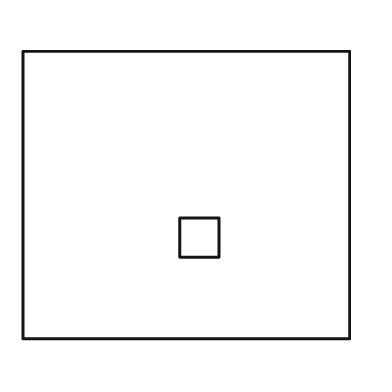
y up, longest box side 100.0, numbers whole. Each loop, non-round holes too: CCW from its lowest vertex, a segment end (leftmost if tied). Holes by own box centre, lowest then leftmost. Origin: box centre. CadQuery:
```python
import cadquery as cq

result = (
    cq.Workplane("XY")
    .moveTo(-50.0, -44.0)
    .lineTo(50.0, -44.0)
    .lineTo(50.0, 44.0)
    .lineTo(-50.0, 44.0)
    .close()
    .moveTo(-2.0, -19.0)
    .lineTo(10.0, -19.0)
    .lineTo(10.0, -7.0)
    .lineTo(-2.0, -7.0)
    .close()
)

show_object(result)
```